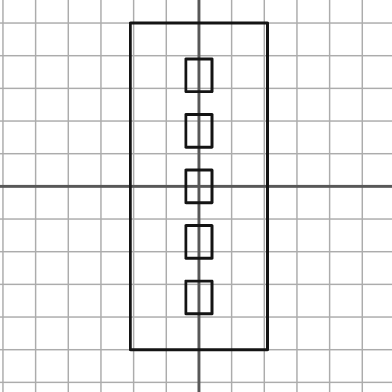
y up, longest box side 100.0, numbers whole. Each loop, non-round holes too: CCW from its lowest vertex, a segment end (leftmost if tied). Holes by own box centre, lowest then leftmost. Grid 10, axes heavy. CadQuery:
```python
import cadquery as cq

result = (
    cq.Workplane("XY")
    .moveTo(-21.0, -50.0)
    .lineTo(21.0, -50.0)
    .lineTo(21.0, 50.0)
    .lineTo(-21.0, 50.0)
    .close()
    .moveTo(-4.0, -39.0)
    .lineTo(4.0, -39.0)
    .lineTo(4.0, -29.0)
    .lineTo(-4.0, -29.0)
    .close()
    .moveTo(-4.0, -22.0)
    .lineTo(4.0, -22.0)
    .lineTo(4.0, -12.0)
    .lineTo(-4.0, -12.0)
    .close()
    .moveTo(-4.0, -5.0)
    .lineTo(4.0, -5.0)
    .lineTo(4.0, 5.0)
    .lineTo(-4.0, 5.0)
    .close()
    .moveTo(-4.0, 12.0)
    .lineTo(4.0, 12.0)
    .lineTo(4.0, 22.0)
    .lineTo(-4.0, 22.0)
    .close()
    .moveTo(-4.0, 29.0)
    .lineTo(4.0, 29.0)
    .lineTo(4.0, 39.0)
    .lineTo(-4.0, 39.0)
    .close()
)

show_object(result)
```